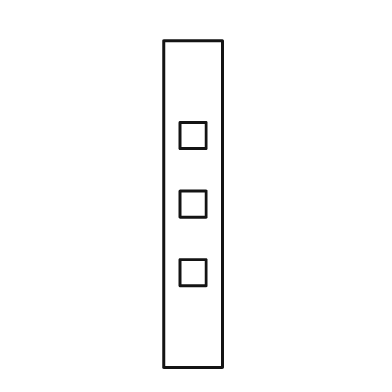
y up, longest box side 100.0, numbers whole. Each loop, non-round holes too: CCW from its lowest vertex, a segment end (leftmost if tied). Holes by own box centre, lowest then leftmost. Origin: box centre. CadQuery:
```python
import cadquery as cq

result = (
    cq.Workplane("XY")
    .moveTo(-9.0, -50.0)
    .lineTo(9.0, -50.0)
    .lineTo(9.0, 50.0)
    .lineTo(-9.0, 50.0)
    .close()
    .moveTo(-4.0, -25.0)
    .lineTo(4.0, -25.0)
    .lineTo(4.0, -17.0)
    .lineTo(-4.0, -17.0)
    .close()
    .moveTo(-4.0, -4.0)
    .lineTo(4.0, -4.0)
    .lineTo(4.0, 4.0)
    .lineTo(-4.0, 4.0)
    .close()
    .moveTo(-4.0, 17.0)
    .lineTo(4.0, 17.0)
    .lineTo(4.0, 25.0)
    .lineTo(-4.0, 25.0)
    .close()
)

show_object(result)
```